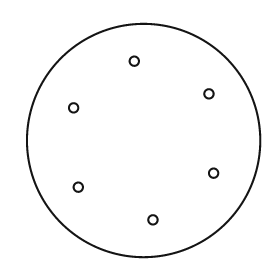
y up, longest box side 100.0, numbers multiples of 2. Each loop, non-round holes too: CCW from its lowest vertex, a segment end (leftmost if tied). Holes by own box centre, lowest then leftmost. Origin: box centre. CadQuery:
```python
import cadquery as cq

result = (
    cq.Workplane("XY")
    .moveTo(0.0, 0.0)
    .circle(50.0)
    .moveTo(4.0, -34.0)
    .circle(2.0)
    .moveTo(-28.0, -20.0)
    .circle(2.0)
    .moveTo(30.0, -14.0)
    .circle(2.0)
    .moveTo(-30.0, 14.0)
    .circle(2.0)
    .moveTo(28.0, 20.0)
    .circle(2.0)
    .moveTo(-4.0, 34.0)
    .circle(2.0)
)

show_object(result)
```